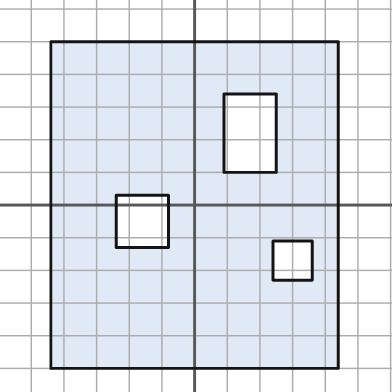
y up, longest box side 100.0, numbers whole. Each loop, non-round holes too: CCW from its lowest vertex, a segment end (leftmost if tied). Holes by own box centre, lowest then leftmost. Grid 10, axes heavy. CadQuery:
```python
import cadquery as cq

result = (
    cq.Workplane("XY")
    .moveTo(-44.0, -50.0)
    .lineTo(44.0, -50.0)
    .lineTo(44.0, 50.0)
    .lineTo(-44.0, 50.0)
    .close()
    .moveTo(24.0, -23.0)
    .lineTo(36.0, -23.0)
    .lineTo(36.0, -11.0)
    .lineTo(24.0, -11.0)
    .close()
    .moveTo(-24.0, -13.0)
    .lineTo(-8.0, -13.0)
    .lineTo(-8.0, 3.0)
    .lineTo(-24.0, 3.0)
    .close()
    .moveTo(9.0, 10.0)
    .lineTo(25.0, 10.0)
    .lineTo(25.0, 34.0)
    .lineTo(9.0, 34.0)
    .close()
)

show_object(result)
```